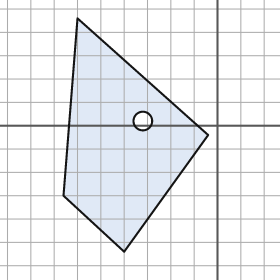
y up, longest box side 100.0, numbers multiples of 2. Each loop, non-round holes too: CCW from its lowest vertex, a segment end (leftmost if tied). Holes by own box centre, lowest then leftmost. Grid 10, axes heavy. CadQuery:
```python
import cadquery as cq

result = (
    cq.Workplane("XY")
    .moveTo(-40.0, -54.0)
    .lineTo(-4.0, -4.0)
    .lineTo(-60.0, 46.0)
    .lineTo(-66.0, -30.0)
    .close()
    .moveTo(-32.0, 2.0)
    .circle(4.0)
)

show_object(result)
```